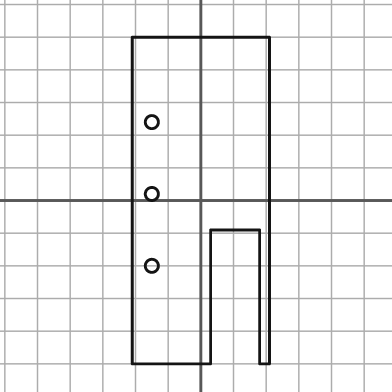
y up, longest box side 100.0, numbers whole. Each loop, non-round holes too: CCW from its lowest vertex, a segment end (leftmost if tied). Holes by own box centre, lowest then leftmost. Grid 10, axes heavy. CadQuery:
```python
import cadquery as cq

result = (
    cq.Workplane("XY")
    .moveTo(-21.0, -50.0)
    .lineTo(3.0, -50.0)
    .lineTo(3.0, -9.0)
    .lineTo(18.0, -9.0)
    .lineTo(18.0, -50.0)
    .lineTo(21.0, -50.0)
    .lineTo(21.0, 50.0)
    .lineTo(-21.0, 50.0)
    .close()
    .moveTo(-15.0, -20.0)
    .circle(2.0)
    .moveTo(-15.0, 2.0)
    .circle(2.0)
    .moveTo(-15.0, 24.0)
    .circle(2.0)
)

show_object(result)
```